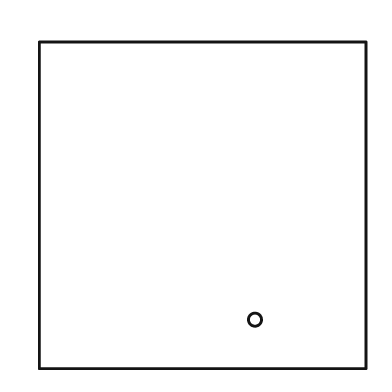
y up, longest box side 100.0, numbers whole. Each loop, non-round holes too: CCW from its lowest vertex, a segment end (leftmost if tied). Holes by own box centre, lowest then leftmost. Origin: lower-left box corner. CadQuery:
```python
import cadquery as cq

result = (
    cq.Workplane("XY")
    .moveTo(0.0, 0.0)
    .lineTo(100.0, 0.0)
    .lineTo(100.0, 100.0)
    .lineTo(0.0, 100.0)
    .close()
    .moveTo(66.0, 15.0)
    .circle(2.0)
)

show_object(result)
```